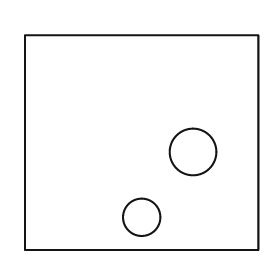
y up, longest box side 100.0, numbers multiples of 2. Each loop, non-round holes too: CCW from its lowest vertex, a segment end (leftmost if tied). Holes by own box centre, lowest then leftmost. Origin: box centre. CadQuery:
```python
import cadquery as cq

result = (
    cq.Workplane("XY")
    .moveTo(-50.0, -46.0)
    .lineTo(50.0, -46.0)
    .lineTo(50.0, 46.0)
    .lineTo(-50.0, 46.0)
    .close()
    .moveTo(0.0, -32.0)
    .circle(8.0)
    .moveTo(22.0, -4.0)
    .circle(10.0)
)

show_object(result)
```